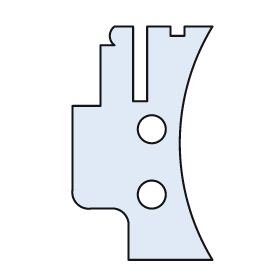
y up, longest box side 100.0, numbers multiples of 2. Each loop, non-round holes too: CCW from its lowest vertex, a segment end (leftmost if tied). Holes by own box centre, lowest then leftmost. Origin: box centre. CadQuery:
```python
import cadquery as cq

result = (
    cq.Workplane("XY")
    .moveTo(-6.0, -50.0)
    .lineTo(30.0, -50.0)
    .threePointArc((16.0, 0.0), (30.0, 50.0))
    .lineTo(18.0, 50.0)
    .lineTo(18.0, 46.0)
    .lineTo(12.0, 46.0)
    .lineTo(12.0, 50.0)
    .lineTo(2.0, 50.0)
    .lineTo(2.0, 18.0)
    .lineTo(-4.0, 18.0)
    .lineTo(-4.0, 50.0)
    .lineTo(-12.0, 50.0)
    .threePointArc((-14.0, 46.0), (-12.0, 42.0))
    .lineTo(-18.0, 42.0)
    .lineTo(-18.0, 16.0)
    .lineTo(-30.0, 16.0)
    .lineTo(-30.0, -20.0)
    .threePointArc((-28.0, -26.0), (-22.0, -28.0))
    .lineTo(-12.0, -28.0)
    .threePointArc((-8.0, -30.0), (-6.0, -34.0))
    .close()
    .moveTo(4.0, -22.0)
    .circle(6.0)
    .moveTo(4.0, 6.0)
    .circle(6.0)
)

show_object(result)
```